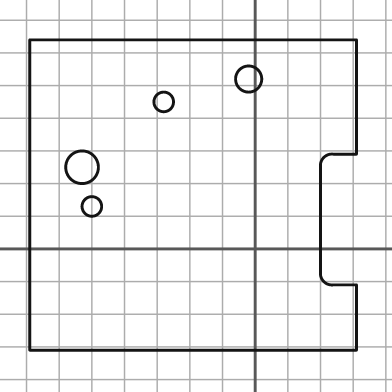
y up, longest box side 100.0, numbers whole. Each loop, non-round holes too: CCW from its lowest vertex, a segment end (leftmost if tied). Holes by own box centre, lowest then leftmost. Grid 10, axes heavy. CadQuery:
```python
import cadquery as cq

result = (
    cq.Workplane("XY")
    .moveTo(-69.0, -31.0)
    .lineTo(31.0, -31.0)
    .lineTo(31.0, -11.0)
    .lineTo(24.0, -11.0)
    .threePointArc((21.0, -10.0), (20.0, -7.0))
    .lineTo(20.0, 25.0)
    .threePointArc((21.0, 28.0), (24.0, 29.0))
    .lineTo(31.0, 29.0)
    .lineTo(31.0, 64.0)
    .lineTo(-69.0, 64.0)
    .close()
    .moveTo(-50.0, 13.0)
    .circle(3.0)
    .moveTo(-53.0, 25.0)
    .circle(5.0)
    .moveTo(-28.0, 45.0)
    .circle(3.0)
    .moveTo(-2.0, 52.0)
    .circle(4.0)
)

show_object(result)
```